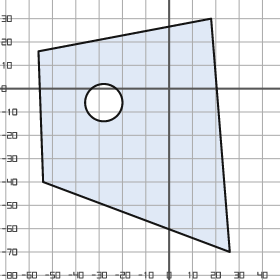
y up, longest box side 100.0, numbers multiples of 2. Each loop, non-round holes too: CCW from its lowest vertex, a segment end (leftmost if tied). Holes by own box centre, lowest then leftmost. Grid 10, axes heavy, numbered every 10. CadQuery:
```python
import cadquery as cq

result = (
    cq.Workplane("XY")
    .moveTo(26.0, -70.0)
    .lineTo(18.0, 30.0)
    .lineTo(-56.0, 16.0)
    .lineTo(-54.0, -40.0)
    .close()
    .moveTo(-28.0, -6.0)
    .circle(8.0)
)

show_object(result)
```